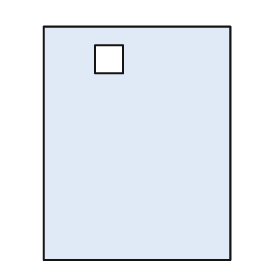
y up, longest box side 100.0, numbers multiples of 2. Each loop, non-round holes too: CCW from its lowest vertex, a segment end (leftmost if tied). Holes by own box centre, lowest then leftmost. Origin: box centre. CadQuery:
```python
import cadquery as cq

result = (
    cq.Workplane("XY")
    .moveTo(-40.0, -50.0)
    .lineTo(40.0, -50.0)
    .lineTo(40.0, 50.0)
    .lineTo(-40.0, 50.0)
    .close()
    .moveTo(-18.0, 30.0)
    .lineTo(-6.0, 30.0)
    .lineTo(-6.0, 42.0)
    .lineTo(-18.0, 42.0)
    .close()
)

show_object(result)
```